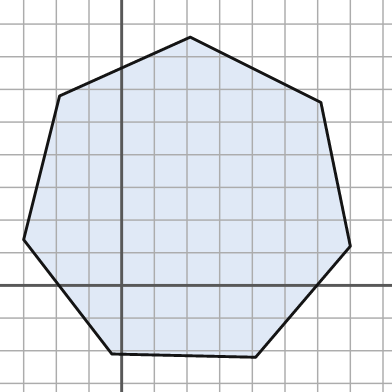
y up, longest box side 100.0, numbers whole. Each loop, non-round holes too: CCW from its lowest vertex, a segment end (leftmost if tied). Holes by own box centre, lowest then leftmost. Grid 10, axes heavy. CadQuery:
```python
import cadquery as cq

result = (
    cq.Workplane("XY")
    .moveTo(41.0, -22.0)
    .lineTo(70.0, 12.0)
    .lineTo(61.0, 56.0)
    .lineTo(21.0, 76.0)
    .lineTo(-19.0, 58.0)
    .lineTo(-30.0, 14.0)
    .lineTo(-3.0, -21.0)
    .close()
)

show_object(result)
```